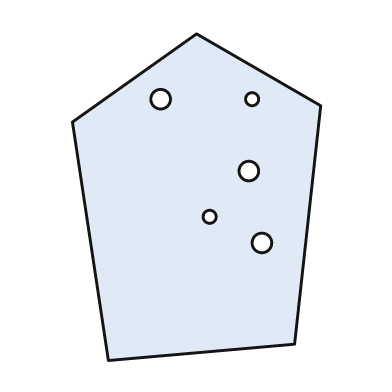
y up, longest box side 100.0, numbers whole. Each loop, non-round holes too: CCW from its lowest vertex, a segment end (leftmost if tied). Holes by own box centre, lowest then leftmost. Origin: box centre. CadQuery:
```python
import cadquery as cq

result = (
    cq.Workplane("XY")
    .moveTo(-27.0, -50.0)
    .lineTo(30.0, -45.0)
    .lineTo(38.0, 28.0)
    .lineTo(0.0, 50.0)
    .lineTo(-38.0, 23.0)
    .close()
    .moveTo(20.0, -14.0)
    .circle(3.0)
    .moveTo(4.0, -6.0)
    .circle(2.0)
    .moveTo(16.0, 8.0)
    .circle(3.0)
    .moveTo(-11.0, 30.0)
    .circle(3.0)
    .moveTo(17.0, 30.0)
    .circle(2.0)
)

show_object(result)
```